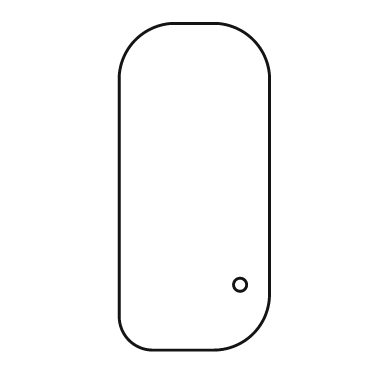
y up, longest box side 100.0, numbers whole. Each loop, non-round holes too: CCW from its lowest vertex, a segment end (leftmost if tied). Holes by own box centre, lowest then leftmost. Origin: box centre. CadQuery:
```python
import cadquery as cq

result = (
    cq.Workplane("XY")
    .moveTo(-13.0, -50.0)
    .lineTo(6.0, -50.0)
    .threePointArc((18.0, -45.0), (23.0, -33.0))
    .lineTo(23.0, 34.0)
    .threePointArc((18.0, 45.0), (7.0, 50.0))
    .lineTo(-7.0, 50.0)
    .threePointArc((-18.0, 45.0), (-23.0, 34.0))
    .lineTo(-23.0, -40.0)
    .threePointArc((-20.0, -47.0), (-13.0, -50.0))
    .close()
    .moveTo(14.0, -30.0)
    .circle(2.0)
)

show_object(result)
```